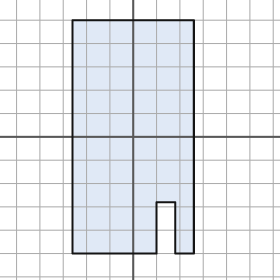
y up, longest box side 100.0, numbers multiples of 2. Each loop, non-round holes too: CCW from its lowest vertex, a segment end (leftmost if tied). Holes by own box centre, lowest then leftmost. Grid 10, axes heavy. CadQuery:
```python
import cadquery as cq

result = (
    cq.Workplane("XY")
    .moveTo(-26.0, -50.0)
    .lineTo(10.0, -50.0)
    .lineTo(10.0, -28.0)
    .lineTo(18.0, -28.0)
    .lineTo(18.0, -50.0)
    .lineTo(26.0, -50.0)
    .lineTo(26.0, 50.0)
    .lineTo(-26.0, 50.0)
    .close()
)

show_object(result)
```